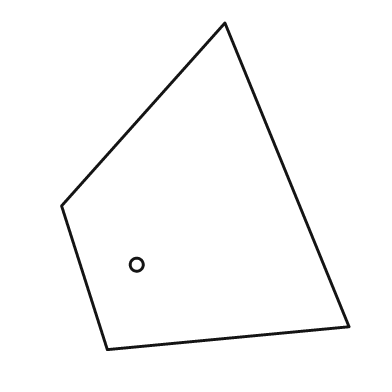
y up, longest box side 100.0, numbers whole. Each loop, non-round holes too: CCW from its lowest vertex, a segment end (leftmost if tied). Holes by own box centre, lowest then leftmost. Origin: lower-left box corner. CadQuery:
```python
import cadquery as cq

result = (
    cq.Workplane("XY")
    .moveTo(14.0, 0.0)
    .lineTo(88.0, 7.0)
    .lineTo(50.0, 100.0)
    .lineTo(0.0, 44.0)
    .close()
    .moveTo(23.0, 26.0)
    .circle(2.0)
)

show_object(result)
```